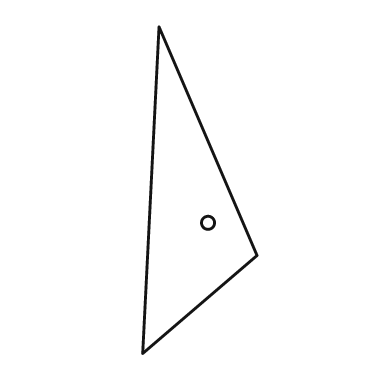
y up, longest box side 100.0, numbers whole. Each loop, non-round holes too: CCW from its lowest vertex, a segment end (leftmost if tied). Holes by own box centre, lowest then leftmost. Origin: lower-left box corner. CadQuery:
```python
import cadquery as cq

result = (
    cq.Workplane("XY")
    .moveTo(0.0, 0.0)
    .lineTo(35.0, 30.0)
    .lineTo(5.0, 100.0)
    .close()
    .moveTo(20.0, 40.0)
    .circle(2.0)
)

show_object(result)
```